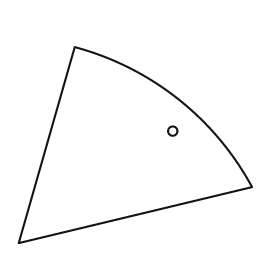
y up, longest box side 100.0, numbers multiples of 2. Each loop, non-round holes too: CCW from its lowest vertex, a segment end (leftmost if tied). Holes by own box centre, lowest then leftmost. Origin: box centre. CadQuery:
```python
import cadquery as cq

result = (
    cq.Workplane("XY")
    .moveTo(-50.0, -42.0)
    .lineTo(50.0, -18.0)
    .threePointArc((18.0, 20.0), (-26.0, 42.0))
    .close()
    .moveTo(16.0, 6.0)
    .circle(2.0)
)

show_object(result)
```